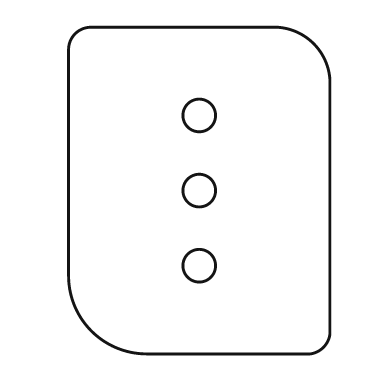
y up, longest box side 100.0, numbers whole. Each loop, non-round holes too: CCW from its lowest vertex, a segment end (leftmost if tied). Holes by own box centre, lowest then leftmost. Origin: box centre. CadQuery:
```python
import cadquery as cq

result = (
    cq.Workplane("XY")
    .moveTo(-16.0, -50.0)
    .lineTo(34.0, -50.0)
    .threePointArc((38.0, -48.0), (40.0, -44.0))
    .lineTo(40.0, 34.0)
    .threePointArc((35.0, 45.0), (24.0, 50.0))
    .lineTo(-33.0, 50.0)
    .threePointArc((-38.0, 48.0), (-40.0, 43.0))
    .lineTo(-40.0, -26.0)
    .threePointArc((-33.0, -43.0), (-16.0, -50.0))
    .close()
    .moveTo(0.0, -23.0)
    .circle(5.0)
    .moveTo(0.0, 0.0)
    .circle(5.0)
    .moveTo(0.0, 23.0)
    .circle(5.0)
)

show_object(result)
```